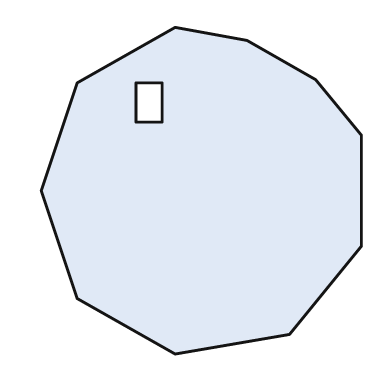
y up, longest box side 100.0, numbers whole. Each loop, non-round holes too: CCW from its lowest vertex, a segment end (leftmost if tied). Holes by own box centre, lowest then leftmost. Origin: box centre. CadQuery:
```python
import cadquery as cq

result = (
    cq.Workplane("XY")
    .moveTo(-8.0, -50.0)
    .lineTo(27.0, -44.0)
    .lineTo(49.0, -17.0)
    .lineTo(49.0, 17.0)
    .lineTo(35.0, 34.0)
    .lineTo(14.0, 46.0)
    .lineTo(-8.0, 50.0)
    .lineTo(-38.0, 33.0)
    .lineTo(-49.0, 0.0)
    .lineTo(-38.0, -33.0)
    .close()
    .moveTo(-20.0, 21.0)
    .lineTo(-12.0, 21.0)
    .lineTo(-12.0, 33.0)
    .lineTo(-20.0, 33.0)
    .close()
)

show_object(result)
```